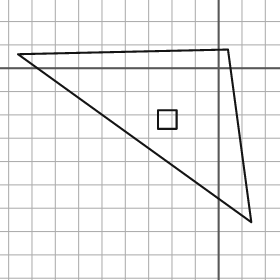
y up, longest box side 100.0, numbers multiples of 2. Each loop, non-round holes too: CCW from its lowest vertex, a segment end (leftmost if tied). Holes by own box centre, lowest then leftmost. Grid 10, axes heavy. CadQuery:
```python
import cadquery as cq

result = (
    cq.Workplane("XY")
    .moveTo(14.0, -66.0)
    .lineTo(4.0, 8.0)
    .lineTo(-86.0, 6.0)
    .close()
    .moveTo(-26.0, -26.0)
    .lineTo(-18.0, -26.0)
    .lineTo(-18.0, -18.0)
    .lineTo(-26.0, -18.0)
    .close()
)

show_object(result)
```